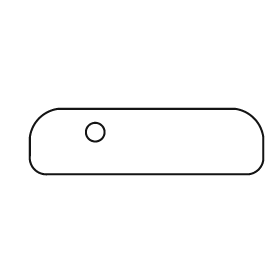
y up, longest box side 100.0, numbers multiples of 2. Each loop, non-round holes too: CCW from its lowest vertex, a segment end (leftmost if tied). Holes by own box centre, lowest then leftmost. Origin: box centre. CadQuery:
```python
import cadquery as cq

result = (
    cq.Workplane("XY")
    .moveTo(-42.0, -14.0)
    .lineTo(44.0, -14.0)
    .threePointArc((48.0, -12.0), (50.0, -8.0))
    .lineTo(50.0, 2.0)
    .threePointArc((46.0, 10.0), (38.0, 14.0))
    .lineTo(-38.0, 14.0)
    .threePointArc((-46.0, 10.0), (-50.0, 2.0))
    .lineTo(-50.0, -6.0)
    .threePointArc((-48.0, -12.0), (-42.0, -14.0))
    .close()
    .moveTo(-22.0, 4.0)
    .circle(4.0)
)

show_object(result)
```